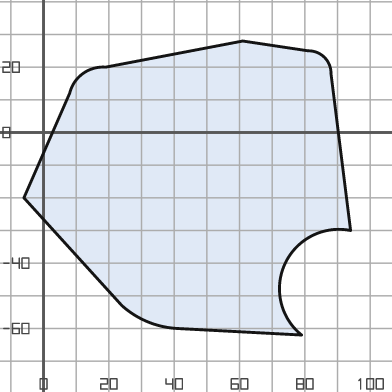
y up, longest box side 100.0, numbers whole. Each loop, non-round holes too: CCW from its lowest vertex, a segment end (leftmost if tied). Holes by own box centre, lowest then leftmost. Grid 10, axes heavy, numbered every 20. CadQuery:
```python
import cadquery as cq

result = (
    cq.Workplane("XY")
    .moveTo(79.0, -62.0)
    .threePointArc((74.0, -40.0), (94.0, -30.0))
    .lineTo(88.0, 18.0)
    .threePointArc((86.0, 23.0), (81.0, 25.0))
    .lineTo(61.0, 28.0)
    .lineTo(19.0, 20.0)
    .threePointArc((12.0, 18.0), (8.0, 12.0))
    .lineTo(-6.0, -20.0)
    .lineTo(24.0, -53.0)
    .threePointArc((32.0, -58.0), (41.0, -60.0))
    .close()
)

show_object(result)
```